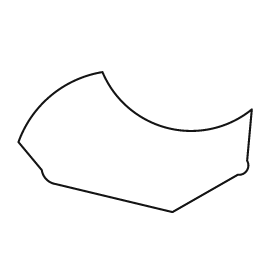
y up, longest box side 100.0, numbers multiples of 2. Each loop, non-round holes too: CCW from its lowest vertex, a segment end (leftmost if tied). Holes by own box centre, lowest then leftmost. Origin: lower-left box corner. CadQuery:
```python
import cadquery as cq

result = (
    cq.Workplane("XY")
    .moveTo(66.0, 0.0)
    .lineTo(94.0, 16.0)
    .threePointArc((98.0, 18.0), (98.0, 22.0))
    .lineTo(100.0, 44.0)
    .threePointArc((64.0, 36.0), (36.0, 60.0))
    .threePointArc((14.0, 50.0), (0.0, 30.0))
    .lineTo(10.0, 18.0)
    .threePointArc((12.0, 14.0), (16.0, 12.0))
    .close()
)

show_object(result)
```